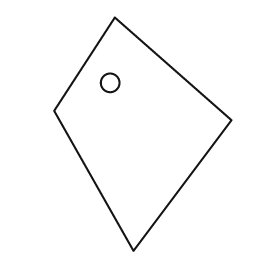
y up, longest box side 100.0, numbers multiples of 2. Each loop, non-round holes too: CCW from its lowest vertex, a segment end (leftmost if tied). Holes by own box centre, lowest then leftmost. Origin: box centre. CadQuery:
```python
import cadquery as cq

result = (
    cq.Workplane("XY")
    .moveTo(-4.0, -50.0)
    .lineTo(38.0, 6.0)
    .lineTo(-12.0, 50.0)
    .lineTo(-38.0, 10.0)
    .close()
    .moveTo(-14.0, 22.0)
    .circle(4.0)
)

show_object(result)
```